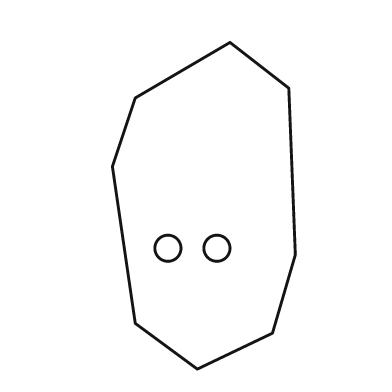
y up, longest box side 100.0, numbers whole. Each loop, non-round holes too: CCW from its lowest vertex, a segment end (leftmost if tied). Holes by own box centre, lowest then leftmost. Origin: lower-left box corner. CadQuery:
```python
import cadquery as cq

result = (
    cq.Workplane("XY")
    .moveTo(26.0, 0.0)
    .lineTo(49.0, 11.0)
    .lineTo(56.0, 35.0)
    .lineTo(54.0, 86.0)
    .lineTo(36.0, 100.0)
    .lineTo(7.0, 83.0)
    .lineTo(0.0, 62.0)
    .lineTo(7.0, 14.0)
    .close()
    .moveTo(17.0, 37.0)
    .circle(4.0)
    .moveTo(32.0, 37.0)
    .circle(4.0)
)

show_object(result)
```